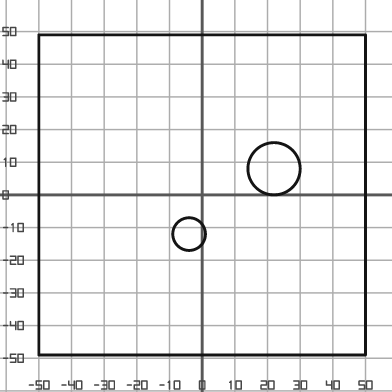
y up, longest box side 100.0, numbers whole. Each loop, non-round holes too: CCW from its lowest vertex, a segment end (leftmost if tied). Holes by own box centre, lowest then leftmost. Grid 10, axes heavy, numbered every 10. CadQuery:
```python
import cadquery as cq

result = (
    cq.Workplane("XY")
    .moveTo(-50.0, -49.0)
    .lineTo(50.0, -49.0)
    .lineTo(50.0, 49.0)
    .lineTo(-50.0, 49.0)
    .close()
    .moveTo(-4.0, -12.0)
    .circle(5.0)
    .moveTo(22.0, 8.0)
    .circle(8.0)
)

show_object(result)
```